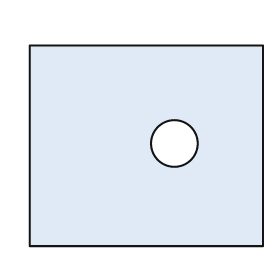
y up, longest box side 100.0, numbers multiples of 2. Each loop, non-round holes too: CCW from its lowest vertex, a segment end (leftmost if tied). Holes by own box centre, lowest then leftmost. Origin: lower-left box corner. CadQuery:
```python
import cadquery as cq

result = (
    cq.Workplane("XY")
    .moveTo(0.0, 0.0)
    .lineTo(100.0, 0.0)
    .lineTo(100.0, 86.0)
    .lineTo(0.0, 86.0)
    .close()
    .moveTo(62.0, 44.0)
    .circle(10.0)
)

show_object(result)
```